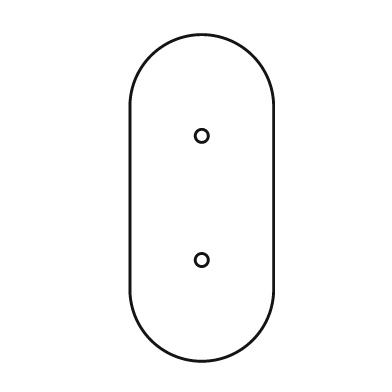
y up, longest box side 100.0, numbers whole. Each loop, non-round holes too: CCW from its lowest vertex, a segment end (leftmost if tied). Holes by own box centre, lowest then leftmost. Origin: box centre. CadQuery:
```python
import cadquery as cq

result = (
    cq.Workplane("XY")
    .moveTo(-22.0, -28.0)
    .threePointArc((0.0, -50.0), (22.0, -28.0))
    .lineTo(22.0, 28.0)
    .threePointArc((0.0, 50.0), (-22.0, 28.0))
    .close()
    .moveTo(0.0, -19.0)
    .circle(2.0)
    .moveTo(0.0, 19.0)
    .circle(2.0)
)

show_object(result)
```